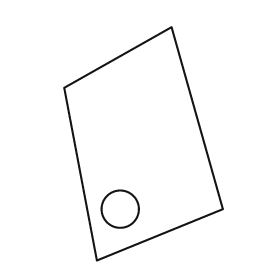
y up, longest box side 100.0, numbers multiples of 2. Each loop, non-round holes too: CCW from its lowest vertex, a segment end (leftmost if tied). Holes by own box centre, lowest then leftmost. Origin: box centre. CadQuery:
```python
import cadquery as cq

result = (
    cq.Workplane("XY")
    .moveTo(-20.0, -50.0)
    .lineTo(34.0, -28.0)
    .lineTo(12.0, 50.0)
    .lineTo(-34.0, 24.0)
    .close()
    .moveTo(-10.0, -28.0)
    .circle(8.0)
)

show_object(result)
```